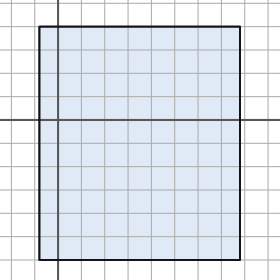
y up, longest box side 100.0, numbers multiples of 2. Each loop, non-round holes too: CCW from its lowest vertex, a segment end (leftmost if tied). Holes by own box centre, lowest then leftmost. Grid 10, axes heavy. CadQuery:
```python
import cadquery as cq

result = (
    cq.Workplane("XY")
    .moveTo(-8.0, -60.0)
    .lineTo(78.0, -60.0)
    .lineTo(78.0, 40.0)
    .lineTo(-8.0, 40.0)
    .close()
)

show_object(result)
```